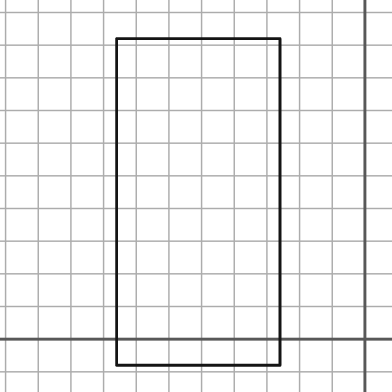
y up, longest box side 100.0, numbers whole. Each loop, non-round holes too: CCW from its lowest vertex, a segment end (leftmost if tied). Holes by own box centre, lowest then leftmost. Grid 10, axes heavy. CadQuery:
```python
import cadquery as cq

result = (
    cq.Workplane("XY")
    .moveTo(-76.0, -8.0)
    .lineTo(-26.0, -8.0)
    .lineTo(-26.0, 92.0)
    .lineTo(-76.0, 92.0)
    .close()
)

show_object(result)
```